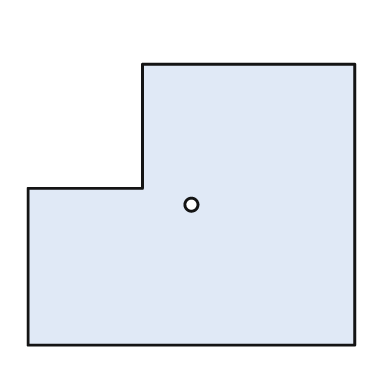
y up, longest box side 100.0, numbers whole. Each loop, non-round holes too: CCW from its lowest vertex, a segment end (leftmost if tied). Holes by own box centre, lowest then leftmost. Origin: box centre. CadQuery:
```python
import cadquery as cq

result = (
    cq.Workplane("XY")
    .moveTo(-50.0, -43.0)
    .lineTo(50.0, -43.0)
    .lineTo(50.0, 43.0)
    .lineTo(-15.0, 43.0)
    .lineTo(-15.0, 5.0)
    .lineTo(-50.0, 5.0)
    .close()
    .moveTo(0.0, 0.0)
    .circle(2.0)
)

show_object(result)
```